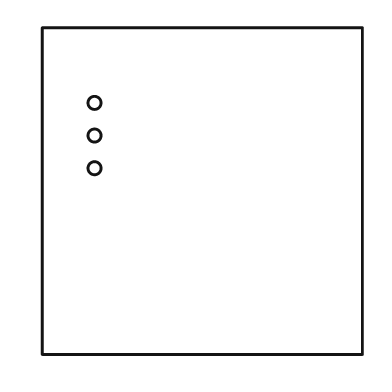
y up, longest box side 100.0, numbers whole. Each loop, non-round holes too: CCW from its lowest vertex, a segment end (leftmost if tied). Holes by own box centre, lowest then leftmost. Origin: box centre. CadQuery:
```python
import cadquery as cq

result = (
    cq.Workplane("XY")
    .moveTo(-49.0, -50.0)
    .lineTo(49.0, -50.0)
    .lineTo(49.0, 50.0)
    .lineTo(-49.0, 50.0)
    .close()
    .moveTo(-33.0, 7.0)
    .circle(2.0)
    .moveTo(-33.0, 17.0)
    .circle(2.0)
    .moveTo(-33.0, 27.0)
    .circle(2.0)
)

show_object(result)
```